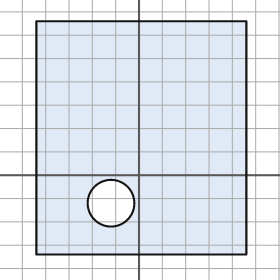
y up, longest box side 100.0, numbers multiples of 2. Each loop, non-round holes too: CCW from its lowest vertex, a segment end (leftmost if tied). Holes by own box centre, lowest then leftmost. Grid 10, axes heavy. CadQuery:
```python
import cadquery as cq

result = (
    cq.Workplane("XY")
    .moveTo(-44.0, -34.0)
    .lineTo(46.0, -34.0)
    .lineTo(46.0, 66.0)
    .lineTo(-44.0, 66.0)
    .close()
    .moveTo(-12.0, -12.0)
    .circle(10.0)
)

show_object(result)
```